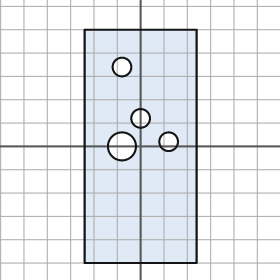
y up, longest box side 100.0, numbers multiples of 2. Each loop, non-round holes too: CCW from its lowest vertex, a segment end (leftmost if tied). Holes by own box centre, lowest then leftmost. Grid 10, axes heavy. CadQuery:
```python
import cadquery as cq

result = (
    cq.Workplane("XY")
    .moveTo(-24.0, -50.0)
    .lineTo(24.0, -50.0)
    .lineTo(24.0, 50.0)
    .lineTo(-24.0, 50.0)
    .close()
    .moveTo(-8.0, 0.0)
    .circle(6.0)
    .moveTo(12.0, 2.0)
    .circle(4.0)
    .moveTo(0.0, 12.0)
    .circle(4.0)
    .moveTo(-8.0, 34.0)
    .circle(4.0)
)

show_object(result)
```